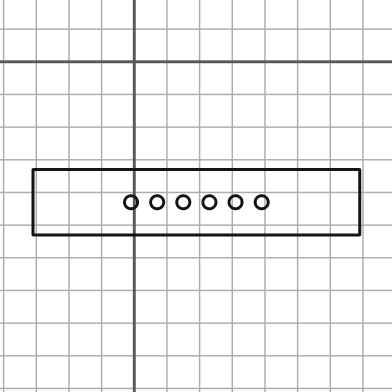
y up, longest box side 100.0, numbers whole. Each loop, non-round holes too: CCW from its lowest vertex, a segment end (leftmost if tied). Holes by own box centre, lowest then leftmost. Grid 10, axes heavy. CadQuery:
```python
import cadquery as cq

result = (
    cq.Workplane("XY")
    .moveTo(-31.0, -53.0)
    .lineTo(69.0, -53.0)
    .lineTo(69.0, -33.0)
    .lineTo(-31.0, -33.0)
    .close()
    .moveTo(-1.0, -43.0)
    .circle(2.0)
    .moveTo(7.0, -43.0)
    .circle(2.0)
    .moveTo(15.0, -43.0)
    .circle(2.0)
    .moveTo(23.0, -43.0)
    .circle(2.0)
    .moveTo(31.0, -43.0)
    .circle(2.0)
    .moveTo(39.0, -43.0)
    .circle(2.0)
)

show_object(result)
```